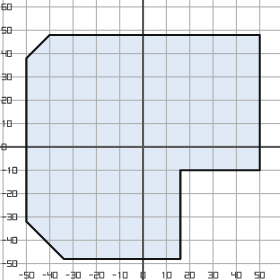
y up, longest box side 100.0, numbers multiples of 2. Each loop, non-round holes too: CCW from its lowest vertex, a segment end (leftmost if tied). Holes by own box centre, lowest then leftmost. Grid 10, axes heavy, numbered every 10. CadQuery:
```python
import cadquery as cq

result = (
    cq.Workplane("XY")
    .moveTo(-34.0, -48.0)
    .lineTo(16.0, -48.0)
    .lineTo(16.0, -10.0)
    .lineTo(50.0, -10.0)
    .lineTo(50.0, 48.0)
    .lineTo(-40.0, 48.0)
    .lineTo(-50.0, 38.0)
    .lineTo(-50.0, -32.0)
    .close()
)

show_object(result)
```